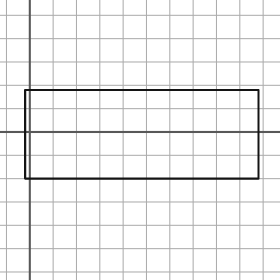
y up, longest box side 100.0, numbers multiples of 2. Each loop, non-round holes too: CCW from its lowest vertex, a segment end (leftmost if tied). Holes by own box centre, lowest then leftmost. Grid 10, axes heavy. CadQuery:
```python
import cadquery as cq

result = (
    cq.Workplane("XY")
    .moveTo(-2.0, -20.0)
    .lineTo(98.0, -20.0)
    .lineTo(98.0, 18.0)
    .lineTo(-2.0, 18.0)
    .close()
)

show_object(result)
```